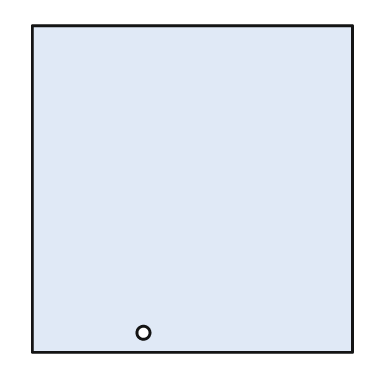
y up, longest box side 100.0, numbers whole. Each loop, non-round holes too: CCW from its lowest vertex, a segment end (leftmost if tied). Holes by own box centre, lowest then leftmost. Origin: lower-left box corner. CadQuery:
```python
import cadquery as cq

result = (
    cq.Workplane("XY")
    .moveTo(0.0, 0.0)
    .lineTo(98.0, 0.0)
    .lineTo(98.0, 100.0)
    .lineTo(0.0, 100.0)
    .close()
    .moveTo(34.0, 6.0)
    .circle(2.0)
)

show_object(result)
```